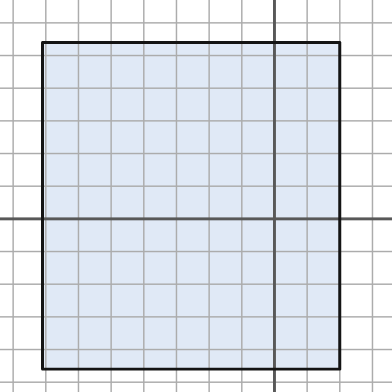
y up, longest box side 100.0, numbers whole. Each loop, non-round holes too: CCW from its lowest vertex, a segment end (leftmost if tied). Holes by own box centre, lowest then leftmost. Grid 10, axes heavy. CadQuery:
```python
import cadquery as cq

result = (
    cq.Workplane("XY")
    .moveTo(-71.0, -46.0)
    .lineTo(20.0, -46.0)
    .lineTo(20.0, 54.0)
    .lineTo(-71.0, 54.0)
    .close()
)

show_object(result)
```